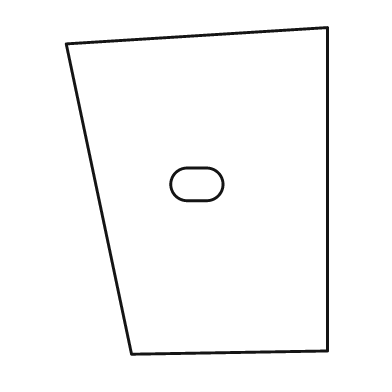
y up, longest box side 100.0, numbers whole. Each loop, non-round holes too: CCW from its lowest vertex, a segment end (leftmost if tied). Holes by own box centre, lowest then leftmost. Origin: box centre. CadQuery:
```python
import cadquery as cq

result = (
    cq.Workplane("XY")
    .moveTo(-20.0, -50.0)
    .lineTo(40.0, -49.0)
    .lineTo(40.0, 50.0)
    .lineTo(-40.0, 45.0)
    .close()
    .moveTo(-3.0, -3.0)
    .lineTo(3.0, -3.0)
    .threePointArc((8.0, 2.0), (3.0, 7.0))
    .lineTo(-3.0, 7.0)
    .threePointArc((-8.0, 2.0), (-3.0, -3.0))
    .close()
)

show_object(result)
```